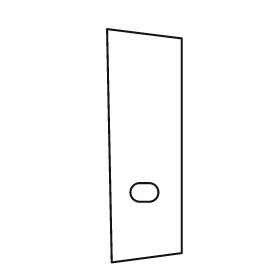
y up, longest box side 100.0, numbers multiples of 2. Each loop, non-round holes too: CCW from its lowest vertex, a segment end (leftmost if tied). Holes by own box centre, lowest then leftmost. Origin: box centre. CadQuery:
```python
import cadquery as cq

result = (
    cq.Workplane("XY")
    .moveTo(-14.0, -50.0)
    .lineTo(16.0, -46.0)
    .lineTo(16.0, 46.0)
    .lineTo(-16.0, 50.0)
    .close()
    .moveTo(-2.0, -24.0)
    .lineTo(2.0, -24.0)
    .threePointArc((6.0, -20.0), (2.0, -16.0))
    .lineTo(-2.0, -16.0)
    .threePointArc((-6.0, -20.0), (-2.0, -24.0))
    .close()
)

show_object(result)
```